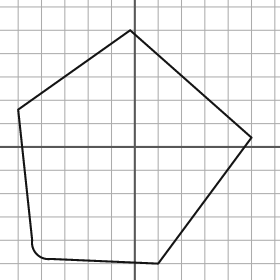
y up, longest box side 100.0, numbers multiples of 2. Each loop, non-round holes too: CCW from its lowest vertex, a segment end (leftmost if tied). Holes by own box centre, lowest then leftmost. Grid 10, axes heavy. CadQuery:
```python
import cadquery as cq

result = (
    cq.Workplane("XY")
    .moveTo(10.0, -50.0)
    .lineTo(50.0, 4.0)
    .lineTo(-2.0, 50.0)
    .lineTo(-50.0, 16.0)
    .lineTo(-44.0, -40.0)
    .threePointArc((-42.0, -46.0), (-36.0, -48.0))
    .close()
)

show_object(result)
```